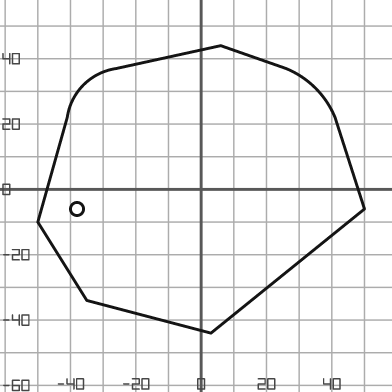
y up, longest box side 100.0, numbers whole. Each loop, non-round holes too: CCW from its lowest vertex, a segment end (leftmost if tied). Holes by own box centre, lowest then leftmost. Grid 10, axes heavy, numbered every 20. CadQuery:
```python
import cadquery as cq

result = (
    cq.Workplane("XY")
    .moveTo(3.0, -44.0)
    .lineTo(50.0, -6.0)
    .lineTo(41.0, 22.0)
    .threePointArc((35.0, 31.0), (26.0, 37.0))
    .lineTo(6.0, 44.0)
    .lineTo(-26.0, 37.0)
    .threePointArc((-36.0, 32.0), (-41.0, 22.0))
    .lineTo(-50.0, -10.0)
    .lineTo(-35.0, -34.0)
    .close()
    .moveTo(-38.0, -6.0)
    .circle(2.0)
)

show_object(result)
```